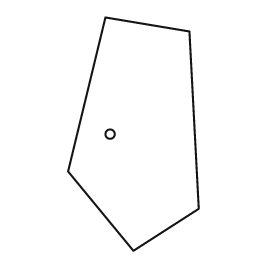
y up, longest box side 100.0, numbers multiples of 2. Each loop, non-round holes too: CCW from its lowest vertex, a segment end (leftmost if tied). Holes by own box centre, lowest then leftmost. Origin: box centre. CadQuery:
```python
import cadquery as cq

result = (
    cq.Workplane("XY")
    .moveTo(0.0, -50.0)
    .lineTo(28.0, -32.0)
    .lineTo(24.0, 44.0)
    .lineTo(-12.0, 50.0)
    .lineTo(-28.0, -16.0)
    .close()
    .moveTo(-10.0, 0.0)
    .circle(2.0)
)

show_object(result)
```